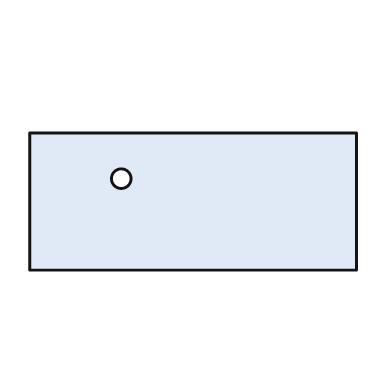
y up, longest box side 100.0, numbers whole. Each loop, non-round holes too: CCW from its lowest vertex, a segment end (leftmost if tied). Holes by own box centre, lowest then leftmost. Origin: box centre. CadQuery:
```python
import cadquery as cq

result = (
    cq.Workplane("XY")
    .moveTo(-50.0, -21.0)
    .lineTo(50.0, -21.0)
    .lineTo(50.0, 21.0)
    .lineTo(-50.0, 21.0)
    .close()
    .moveTo(-22.0, 7.0)
    .circle(3.0)
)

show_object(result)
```